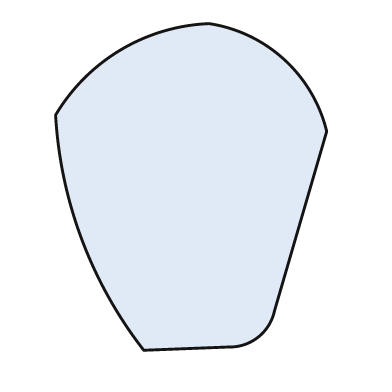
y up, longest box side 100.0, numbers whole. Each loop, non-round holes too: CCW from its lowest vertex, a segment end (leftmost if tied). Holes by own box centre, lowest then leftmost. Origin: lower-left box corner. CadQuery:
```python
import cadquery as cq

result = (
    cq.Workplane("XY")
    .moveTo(27.0, 0.0)
    .lineTo(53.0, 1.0)
    .threePointArc((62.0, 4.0), (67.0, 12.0))
    .lineTo(83.0, 67.0)
    .threePointArc((70.0, 89.0), (47.0, 100.0))
    .threePointArc((20.0, 92.0), (0.0, 72.0))
    .threePointArc((8.0, 34.0), (27.0, 0.0))
    .close()
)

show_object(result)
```